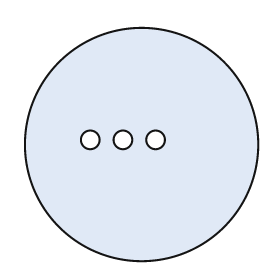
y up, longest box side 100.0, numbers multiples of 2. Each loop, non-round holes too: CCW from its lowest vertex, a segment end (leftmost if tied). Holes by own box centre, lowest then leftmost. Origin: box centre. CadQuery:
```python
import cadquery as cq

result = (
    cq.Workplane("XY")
    .moveTo(0.0, 0.0)
    .circle(50.0)
    .moveTo(-22.0, 2.0)
    .circle(4.0)
    .moveTo(-8.0, 2.0)
    .circle(4.0)
    .moveTo(6.0, 2.0)
    .circle(4.0)
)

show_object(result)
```